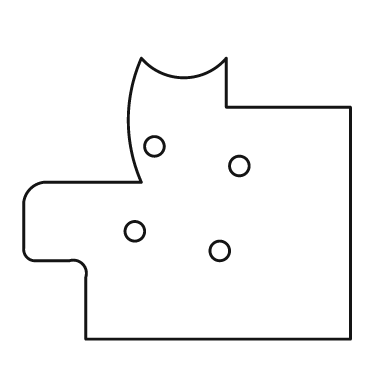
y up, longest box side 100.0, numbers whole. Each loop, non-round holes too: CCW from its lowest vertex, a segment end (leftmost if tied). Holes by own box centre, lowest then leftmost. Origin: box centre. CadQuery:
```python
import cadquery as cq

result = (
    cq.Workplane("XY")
    .moveTo(-31.0, -43.0)
    .lineTo(50.0, -43.0)
    .lineTo(50.0, 28.0)
    .lineTo(12.0, 28.0)
    .lineTo(12.0, 43.0)
    .threePointArc((-1.0, 37.0), (-14.0, 43.0))
    .threePointArc((-18.0, 24.0), (-14.0, 5.0))
    .lineTo(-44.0, 5.0)
    .threePointArc((-48.0, 3.0), (-50.0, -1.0))
    .lineTo(-50.0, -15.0)
    .threePointArc((-49.0, -18.0), (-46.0, -19.0))
    .lineTo(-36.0, -19.0)
    .threePointArc((-32.0, -20.0), (-31.0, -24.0))
    .close()
    .moveTo(10.0, -16.0)
    .circle(3.0)
    .moveTo(-16.0, -10.0)
    .circle(3.0)
    .moveTo(16.0, 10.0)
    .circle(3.0)
    .moveTo(-10.0, 16.0)
    .circle(3.0)
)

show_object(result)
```